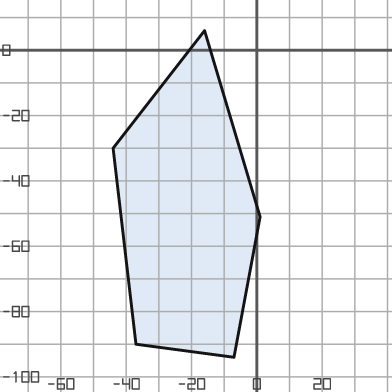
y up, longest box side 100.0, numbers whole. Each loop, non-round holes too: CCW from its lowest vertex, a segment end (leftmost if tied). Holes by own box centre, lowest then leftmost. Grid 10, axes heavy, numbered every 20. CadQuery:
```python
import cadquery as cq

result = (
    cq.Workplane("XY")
    .moveTo(-7.0, -94.0)
    .lineTo(1.0, -51.0)
    .lineTo(-16.0, 6.0)
    .lineTo(-44.0, -30.0)
    .lineTo(-37.0, -90.0)
    .close()
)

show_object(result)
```